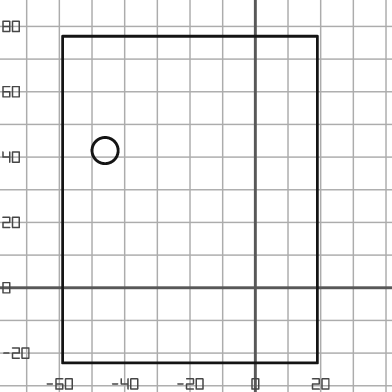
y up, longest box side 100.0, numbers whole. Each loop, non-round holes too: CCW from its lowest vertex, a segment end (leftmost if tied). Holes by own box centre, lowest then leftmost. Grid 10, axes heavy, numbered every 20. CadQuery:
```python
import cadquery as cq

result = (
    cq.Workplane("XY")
    .moveTo(-59.0, -23.0)
    .lineTo(19.0, -23.0)
    .lineTo(19.0, 77.0)
    .lineTo(-59.0, 77.0)
    .close()
    .moveTo(-46.0, 42.0)
    .circle(4.0)
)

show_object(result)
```